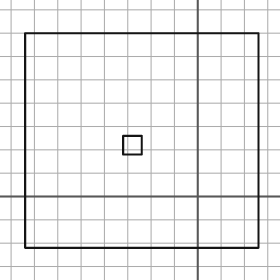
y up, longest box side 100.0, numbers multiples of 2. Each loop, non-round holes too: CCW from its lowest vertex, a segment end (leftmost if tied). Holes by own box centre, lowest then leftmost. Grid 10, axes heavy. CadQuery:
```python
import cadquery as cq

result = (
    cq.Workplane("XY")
    .moveTo(-74.0, -22.0)
    .lineTo(26.0, -22.0)
    .lineTo(26.0, 70.0)
    .lineTo(-74.0, 70.0)
    .close()
    .moveTo(-32.0, 18.0)
    .lineTo(-24.0, 18.0)
    .lineTo(-24.0, 26.0)
    .lineTo(-32.0, 26.0)
    .close()
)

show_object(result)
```